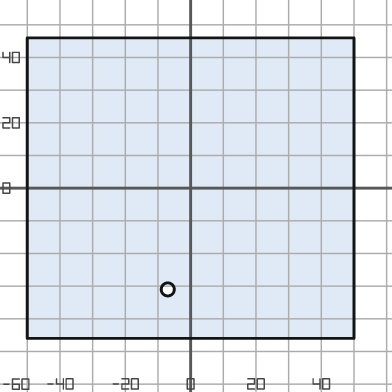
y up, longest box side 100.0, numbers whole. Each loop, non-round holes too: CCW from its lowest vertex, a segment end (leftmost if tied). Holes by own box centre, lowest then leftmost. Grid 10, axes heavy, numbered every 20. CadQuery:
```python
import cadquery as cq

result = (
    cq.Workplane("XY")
    .moveTo(-50.0, -46.0)
    .lineTo(50.0, -46.0)
    .lineTo(50.0, 46.0)
    .lineTo(-50.0, 46.0)
    .close()
    .moveTo(-7.0, -31.0)
    .circle(2.0)
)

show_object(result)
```